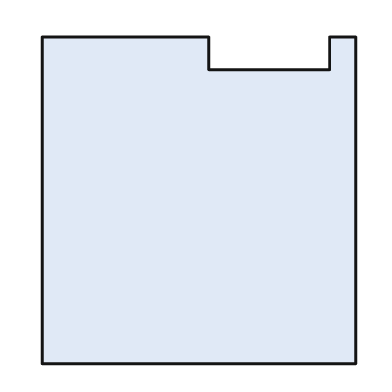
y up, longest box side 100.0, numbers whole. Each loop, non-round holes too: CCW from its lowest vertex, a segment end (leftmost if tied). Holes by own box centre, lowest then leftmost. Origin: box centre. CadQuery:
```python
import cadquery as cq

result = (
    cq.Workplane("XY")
    .moveTo(-48.0, -50.0)
    .lineTo(48.0, -50.0)
    .lineTo(48.0, 50.0)
    .lineTo(40.0, 50.0)
    .lineTo(40.0, 40.0)
    .lineTo(3.0, 40.0)
    .lineTo(3.0, 50.0)
    .lineTo(-48.0, 50.0)
    .close()
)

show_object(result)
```